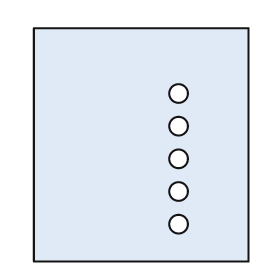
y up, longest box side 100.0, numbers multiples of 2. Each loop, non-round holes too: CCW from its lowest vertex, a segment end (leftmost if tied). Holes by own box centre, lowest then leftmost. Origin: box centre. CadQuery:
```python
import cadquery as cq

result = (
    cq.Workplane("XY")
    .moveTo(-46.0, -50.0)
    .lineTo(46.0, -50.0)
    .lineTo(46.0, 50.0)
    .lineTo(-46.0, 50.0)
    .close()
    .moveTo(16.0, -34.0)
    .circle(4.0)
    .moveTo(16.0, -20.0)
    .circle(4.0)
    .moveTo(16.0, -6.0)
    .circle(4.0)
    .moveTo(16.0, 8.0)
    .circle(4.0)
    .moveTo(16.0, 22.0)
    .circle(4.0)
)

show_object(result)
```